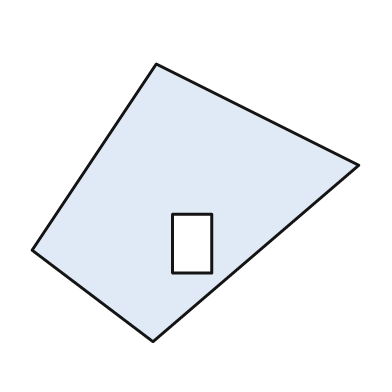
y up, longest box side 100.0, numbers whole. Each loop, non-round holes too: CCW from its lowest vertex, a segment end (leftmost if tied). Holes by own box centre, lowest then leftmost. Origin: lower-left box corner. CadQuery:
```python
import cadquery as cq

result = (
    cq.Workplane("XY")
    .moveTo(37.0, 0.0)
    .lineTo(100.0, 54.0)
    .lineTo(38.0, 85.0)
    .lineTo(0.0, 28.0)
    .close()
    .moveTo(43.0, 21.0)
    .lineTo(55.0, 21.0)
    .lineTo(55.0, 39.0)
    .lineTo(43.0, 39.0)
    .close()
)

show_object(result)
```